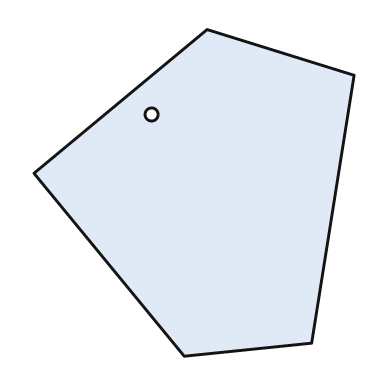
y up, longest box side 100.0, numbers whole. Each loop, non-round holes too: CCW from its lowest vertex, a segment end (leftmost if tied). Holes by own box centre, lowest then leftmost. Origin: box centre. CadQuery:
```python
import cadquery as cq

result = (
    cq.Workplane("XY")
    .moveTo(-3.0, -50.0)
    .lineTo(36.0, -46.0)
    .lineTo(49.0, 36.0)
    .lineTo(4.0, 50.0)
    .lineTo(-49.0, 6.0)
    .close()
    .moveTo(-13.0, 24.0)
    .circle(2.0)
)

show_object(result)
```